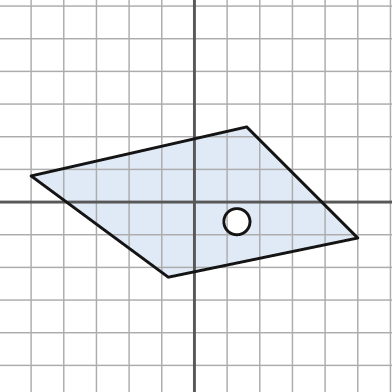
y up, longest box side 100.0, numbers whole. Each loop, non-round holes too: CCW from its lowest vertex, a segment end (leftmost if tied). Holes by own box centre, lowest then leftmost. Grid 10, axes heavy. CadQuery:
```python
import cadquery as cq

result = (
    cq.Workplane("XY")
    .moveTo(-8.0, -23.0)
    .lineTo(50.0, -11.0)
    .lineTo(16.0, 23.0)
    .lineTo(-50.0, 8.0)
    .close()
    .moveTo(13.0, -6.0)
    .circle(4.0)
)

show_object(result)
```